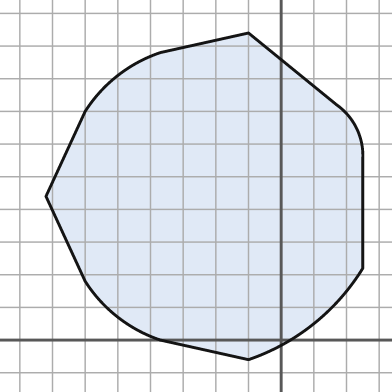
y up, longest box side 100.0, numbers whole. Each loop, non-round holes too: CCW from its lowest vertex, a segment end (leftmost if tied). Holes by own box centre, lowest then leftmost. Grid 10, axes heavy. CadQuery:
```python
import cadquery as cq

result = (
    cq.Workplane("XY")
    .moveTo(-10.0, -6.0)
    .threePointArc((10.0, 5.0), (25.0, 22.0))
    .lineTo(25.0, 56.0)
    .threePointArc((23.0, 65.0), (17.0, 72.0))
    .lineTo(-10.0, 94.0)
    .lineTo(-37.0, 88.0)
    .threePointArc((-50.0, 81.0), (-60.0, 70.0))
    .lineTo(-72.0, 44.0)
    .lineTo(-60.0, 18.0)
    .threePointArc((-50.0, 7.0), (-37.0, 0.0))
    .close()
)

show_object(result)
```